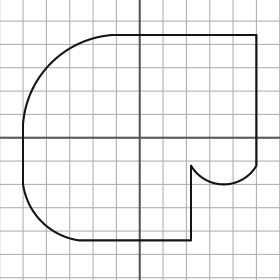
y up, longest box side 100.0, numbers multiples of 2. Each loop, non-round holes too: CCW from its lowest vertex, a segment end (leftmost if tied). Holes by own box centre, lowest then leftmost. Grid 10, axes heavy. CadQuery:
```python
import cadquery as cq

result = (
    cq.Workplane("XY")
    .moveTo(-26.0, -44.0)
    .lineTo(22.0, -44.0)
    .lineTo(22.0, -12.0)
    .threePointArc((36.0, -20.0), (50.0, -12.0))
    .lineTo(50.0, 44.0)
    .lineTo(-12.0, 44.0)
    .threePointArc((-38.0, 32.0), (-50.0, 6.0))
    .lineTo(-50.0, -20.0)
    .threePointArc((-42.0, -36.0), (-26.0, -44.0))
    .close()
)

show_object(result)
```